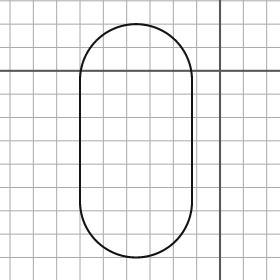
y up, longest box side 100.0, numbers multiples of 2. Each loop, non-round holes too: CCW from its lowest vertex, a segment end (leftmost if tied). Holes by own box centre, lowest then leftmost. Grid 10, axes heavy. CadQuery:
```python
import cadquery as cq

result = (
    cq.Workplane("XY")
    .moveTo(-60.0, -56.0)
    .threePointArc((-36.0, -80.0), (-12.0, -56.0))
    .lineTo(-12.0, -4.0)
    .threePointArc((-36.0, 20.0), (-60.0, -4.0))
    .close()
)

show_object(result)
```